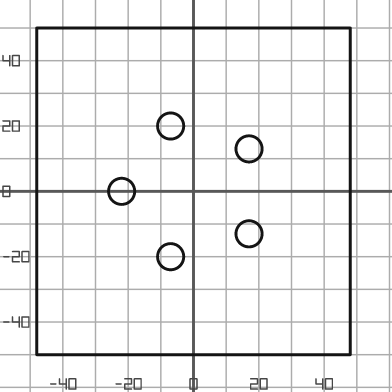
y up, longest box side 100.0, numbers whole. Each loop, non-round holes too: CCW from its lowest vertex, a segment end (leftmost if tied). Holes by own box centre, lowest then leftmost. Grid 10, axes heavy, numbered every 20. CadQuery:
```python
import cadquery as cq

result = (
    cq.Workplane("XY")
    .moveTo(-48.0, -50.0)
    .lineTo(48.0, -50.0)
    .lineTo(48.0, 50.0)
    .lineTo(-48.0, 50.0)
    .close()
    .moveTo(-7.0, -20.0)
    .circle(4.0)
    .moveTo(17.0, -13.0)
    .circle(4.0)
    .moveTo(-22.0, 0.0)
    .circle(4.0)
    .moveTo(17.0, 13.0)
    .circle(4.0)
    .moveTo(-7.0, 20.0)
    .circle(4.0)
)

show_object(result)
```